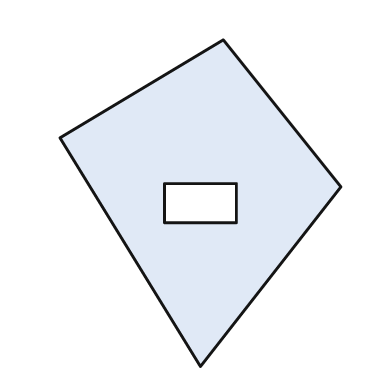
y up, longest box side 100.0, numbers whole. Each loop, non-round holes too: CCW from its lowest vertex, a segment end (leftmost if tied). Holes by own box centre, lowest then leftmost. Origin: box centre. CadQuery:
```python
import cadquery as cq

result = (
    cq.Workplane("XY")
    .moveTo(0.0, -50.0)
    .lineTo(43.0, 5.0)
    .lineTo(7.0, 50.0)
    .lineTo(-43.0, 20.0)
    .close()
    .moveTo(-11.0, -6.0)
    .lineTo(11.0, -6.0)
    .lineTo(11.0, 6.0)
    .lineTo(-11.0, 6.0)
    .close()
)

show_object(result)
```